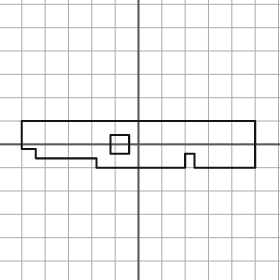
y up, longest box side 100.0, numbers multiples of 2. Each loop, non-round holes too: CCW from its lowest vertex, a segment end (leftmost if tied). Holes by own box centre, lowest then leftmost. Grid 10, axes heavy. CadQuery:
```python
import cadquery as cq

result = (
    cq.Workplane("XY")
    .moveTo(-18.0, -10.0)
    .lineTo(20.0, -10.0)
    .lineTo(20.0, -4.0)
    .lineTo(24.0, -4.0)
    .lineTo(24.0, -10.0)
    .lineTo(50.0, -10.0)
    .lineTo(50.0, 10.0)
    .lineTo(-50.0, 10.0)
    .lineTo(-50.0, -2.0)
    .lineTo(-44.0, -2.0)
    .lineTo(-44.0, -6.0)
    .lineTo(-18.0, -6.0)
    .close()
    .moveTo(-12.0, -4.0)
    .lineTo(-4.0, -4.0)
    .lineTo(-4.0, 4.0)
    .lineTo(-12.0, 4.0)
    .close()
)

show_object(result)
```